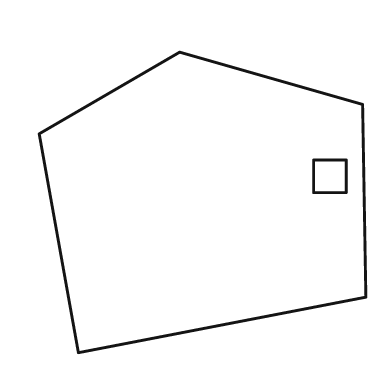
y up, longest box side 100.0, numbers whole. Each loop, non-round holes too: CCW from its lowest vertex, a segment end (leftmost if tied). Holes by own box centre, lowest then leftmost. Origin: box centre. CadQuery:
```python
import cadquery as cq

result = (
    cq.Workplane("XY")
    .moveTo(-38.0, -46.0)
    .lineTo(50.0, -29.0)
    .lineTo(49.0, 30.0)
    .lineTo(-7.0, 46.0)
    .lineTo(-50.0, 21.0)
    .close()
    .moveTo(34.0, 3.0)
    .lineTo(44.0, 3.0)
    .lineTo(44.0, 13.0)
    .lineTo(34.0, 13.0)
    .close()
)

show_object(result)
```